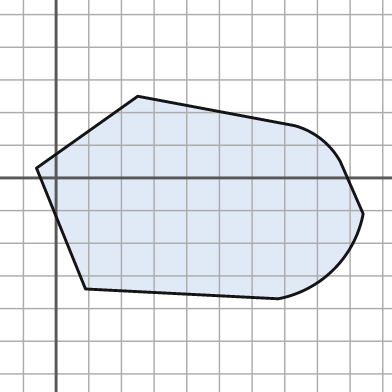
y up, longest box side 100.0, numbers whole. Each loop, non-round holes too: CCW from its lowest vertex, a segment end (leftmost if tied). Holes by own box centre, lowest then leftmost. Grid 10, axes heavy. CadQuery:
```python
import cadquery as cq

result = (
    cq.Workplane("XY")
    .moveTo(68.0, -37.0)
    .threePointArc((85.0, -28.0), (94.0, -11.0))
    .lineTo(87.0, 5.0)
    .threePointArc((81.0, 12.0), (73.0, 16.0))
    .lineTo(25.0, 25.0)
    .lineTo(-6.0, 3.0)
    .lineTo(9.0, -34.0)
    .close()
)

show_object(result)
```